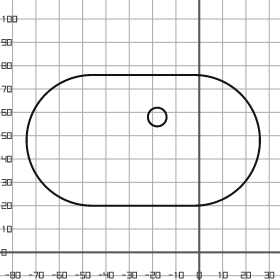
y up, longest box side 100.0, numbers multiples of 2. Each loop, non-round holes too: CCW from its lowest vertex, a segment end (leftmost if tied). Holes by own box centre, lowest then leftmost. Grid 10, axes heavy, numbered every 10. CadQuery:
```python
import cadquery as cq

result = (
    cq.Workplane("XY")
    .moveTo(-46.0, 20.0)
    .lineTo(-2.0, 20.0)
    .threePointArc((26.0, 48.0), (-2.0, 76.0))
    .lineTo(-46.0, 76.0)
    .threePointArc((-74.0, 48.0), (-46.0, 20.0))
    .close()
    .moveTo(-18.0, 58.0)
    .circle(4.0)
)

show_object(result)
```